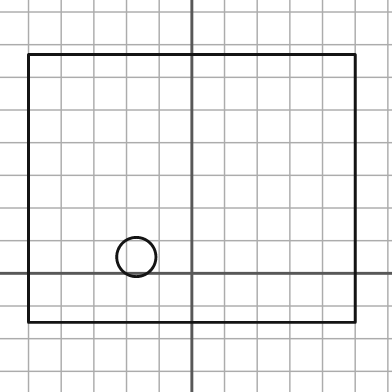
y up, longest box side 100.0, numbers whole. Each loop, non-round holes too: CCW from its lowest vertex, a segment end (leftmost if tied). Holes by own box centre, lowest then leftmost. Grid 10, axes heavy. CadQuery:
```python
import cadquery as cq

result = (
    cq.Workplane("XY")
    .moveTo(-50.0, -15.0)
    .lineTo(50.0, -15.0)
    .lineTo(50.0, 67.0)
    .lineTo(-50.0, 67.0)
    .close()
    .moveTo(-17.0, 5.0)
    .circle(6.0)
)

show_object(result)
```